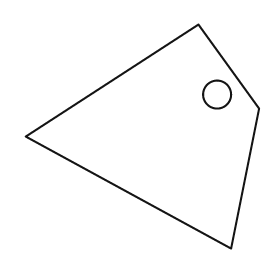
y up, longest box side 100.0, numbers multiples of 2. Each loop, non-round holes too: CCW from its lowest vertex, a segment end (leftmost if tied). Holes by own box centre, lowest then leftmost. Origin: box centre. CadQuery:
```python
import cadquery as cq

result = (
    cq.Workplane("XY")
    .moveTo(38.0, -48.0)
    .lineTo(50.0, 12.0)
    .lineTo(24.0, 48.0)
    .lineTo(-50.0, 0.0)
    .close()
    .moveTo(32.0, 18.0)
    .circle(6.0)
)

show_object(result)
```